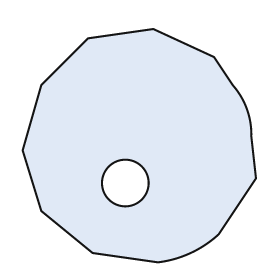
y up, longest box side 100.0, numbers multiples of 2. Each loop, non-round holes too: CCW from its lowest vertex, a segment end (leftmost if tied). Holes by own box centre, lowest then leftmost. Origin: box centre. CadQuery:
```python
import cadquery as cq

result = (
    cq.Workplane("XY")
    .moveTo(8.0, -50.0)
    .threePointArc((22.0, -46.0), (34.0, -38.0))
    .lineTo(50.0, -14.0)
    .lineTo(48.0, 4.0)
    .threePointArc((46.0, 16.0), (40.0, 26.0))
    .lineTo(32.0, 38.0)
    .lineTo(6.0, 50.0)
    .lineTo(-22.0, 46.0)
    .lineTo(-42.0, 26.0)
    .lineTo(-50.0, -2.0)
    .lineTo(-42.0, -28.0)
    .lineTo(-20.0, -46.0)
    .close()
    .moveTo(-6.0, -16.0)
    .circle(10.0)
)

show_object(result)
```